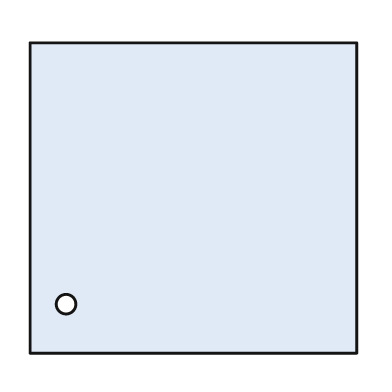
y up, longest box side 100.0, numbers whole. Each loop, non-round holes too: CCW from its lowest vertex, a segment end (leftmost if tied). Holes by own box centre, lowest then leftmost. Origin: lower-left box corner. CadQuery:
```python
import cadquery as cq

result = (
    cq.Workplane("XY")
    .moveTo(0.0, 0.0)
    .lineTo(100.0, 0.0)
    .lineTo(100.0, 95.0)
    .lineTo(0.0, 95.0)
    .close()
    .moveTo(11.0, 15.0)
    .circle(3.0)
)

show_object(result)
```